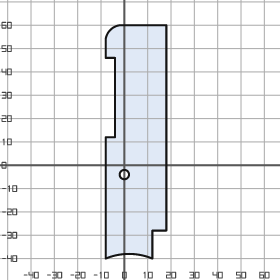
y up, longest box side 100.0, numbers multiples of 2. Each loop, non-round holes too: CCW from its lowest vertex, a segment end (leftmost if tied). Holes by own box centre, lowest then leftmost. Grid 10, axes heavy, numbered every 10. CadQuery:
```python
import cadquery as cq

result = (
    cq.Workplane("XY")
    .moveTo(-8.0, -40.0)
    .threePointArc((2.0, -38.0), (12.0, -40.0))
    .lineTo(12.0, -28.0)
    .lineTo(18.0, -28.0)
    .lineTo(18.0, 60.0)
    .lineTo(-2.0, 60.0)
    .threePointArc((-6.0, 58.0), (-8.0, 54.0))
    .lineTo(-8.0, 46.0)
    .lineTo(-4.0, 46.0)
    .lineTo(-4.0, 12.0)
    .lineTo(-8.0, 12.0)
    .close()
    .moveTo(0.0, -4.0)
    .circle(2.0)
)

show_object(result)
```